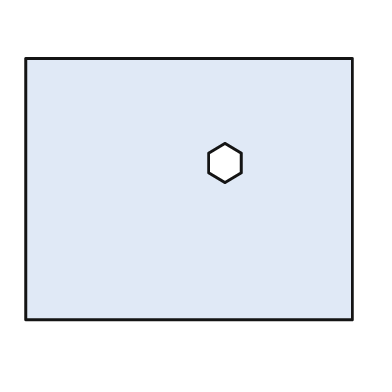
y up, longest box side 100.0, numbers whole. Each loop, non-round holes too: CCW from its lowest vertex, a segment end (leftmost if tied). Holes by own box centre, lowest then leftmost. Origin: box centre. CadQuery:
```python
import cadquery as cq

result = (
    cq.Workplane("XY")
    .moveTo(-50.0, -40.0)
    .lineTo(50.0, -40.0)
    .lineTo(50.0, 40.0)
    .lineTo(-50.0, 40.0)
    .close()
    .moveTo(11.0, 2.0)
    .lineTo(16.0, 5.0)
    .lineTo(16.0, 11.0)
    .lineTo(11.0, 14.0)
    .lineTo(6.0, 11.0)
    .lineTo(6.0, 5.0)
    .close()
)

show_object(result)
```